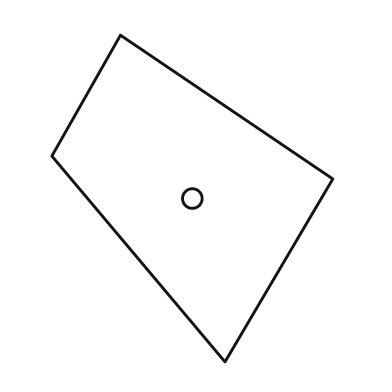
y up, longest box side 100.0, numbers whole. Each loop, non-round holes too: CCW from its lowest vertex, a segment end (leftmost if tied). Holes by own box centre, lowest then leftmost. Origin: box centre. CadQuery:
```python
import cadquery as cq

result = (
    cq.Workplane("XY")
    .moveTo(10.0, -50.0)
    .lineTo(43.0, 6.0)
    .lineTo(-22.0, 50.0)
    .lineTo(-43.0, 13.0)
    .close()
    .moveTo(0.0, 0.0)
    .circle(3.0)
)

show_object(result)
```